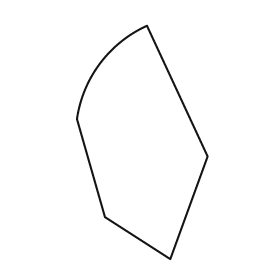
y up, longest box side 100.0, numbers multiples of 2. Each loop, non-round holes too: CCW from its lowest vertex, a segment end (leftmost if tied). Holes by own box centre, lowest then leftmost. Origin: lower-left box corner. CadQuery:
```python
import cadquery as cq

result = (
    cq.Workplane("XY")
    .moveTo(40.0, 0.0)
    .lineTo(56.0, 44.0)
    .lineTo(30.0, 100.0)
    .threePointArc((10.0, 84.0), (0.0, 60.0))
    .lineTo(12.0, 18.0)
    .close()
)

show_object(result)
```